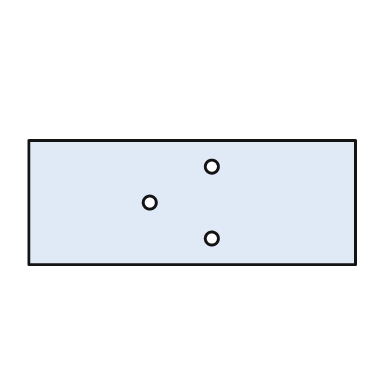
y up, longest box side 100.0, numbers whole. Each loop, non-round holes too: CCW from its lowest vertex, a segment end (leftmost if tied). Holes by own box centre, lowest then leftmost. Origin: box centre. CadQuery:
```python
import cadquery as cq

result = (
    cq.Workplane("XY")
    .moveTo(-50.0, -19.0)
    .lineTo(50.0, -19.0)
    .lineTo(50.0, 19.0)
    .lineTo(-50.0, 19.0)
    .close()
    .moveTo(6.0, -11.0)
    .circle(2.0)
    .moveTo(-13.0, 0.0)
    .circle(2.0)
    .moveTo(6.0, 11.0)
    .circle(2.0)
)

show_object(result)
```